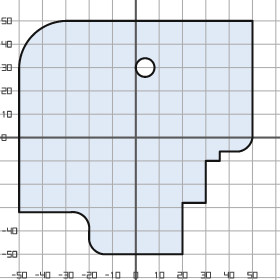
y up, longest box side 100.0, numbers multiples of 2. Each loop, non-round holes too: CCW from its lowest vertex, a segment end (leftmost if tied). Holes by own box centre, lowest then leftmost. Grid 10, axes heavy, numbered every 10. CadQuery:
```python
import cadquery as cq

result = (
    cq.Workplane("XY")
    .moveTo(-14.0, -50.0)
    .lineTo(20.0, -50.0)
    .lineTo(20.0, -28.0)
    .lineTo(30.0, -28.0)
    .lineTo(30.0, -10.0)
    .lineTo(36.0, -10.0)
    .lineTo(36.0, -6.0)
    .lineTo(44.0, -6.0)
    .threePointArc((48.0, -4.0), (50.0, 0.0))
    .lineTo(50.0, 50.0)
    .lineTo(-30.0, 50.0)
    .threePointArc((-44.0, 44.0), (-50.0, 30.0))
    .lineTo(-50.0, -32.0)
    .lineTo(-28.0, -32.0)
    .threePointArc((-22.0, -34.0), (-20.0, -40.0))
    .lineTo(-20.0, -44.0)
    .threePointArc((-18.0, -48.0), (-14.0, -50.0))
    .close()
    .moveTo(4.0, 30.0)
    .circle(4.0)
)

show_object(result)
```